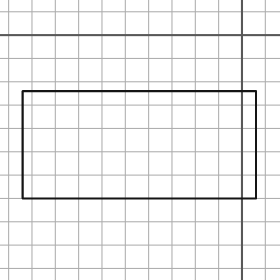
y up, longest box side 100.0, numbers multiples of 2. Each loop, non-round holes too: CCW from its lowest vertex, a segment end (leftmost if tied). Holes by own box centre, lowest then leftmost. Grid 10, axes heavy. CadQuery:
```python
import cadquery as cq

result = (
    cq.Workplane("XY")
    .moveTo(-94.0, -70.0)
    .lineTo(6.0, -70.0)
    .lineTo(6.0, -24.0)
    .lineTo(-94.0, -24.0)
    .close()
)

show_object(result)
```